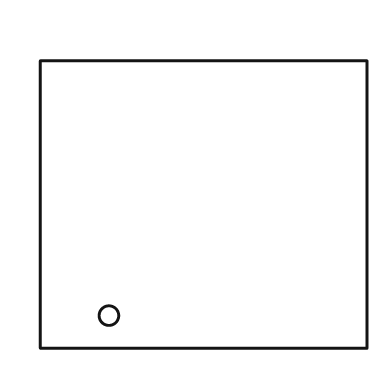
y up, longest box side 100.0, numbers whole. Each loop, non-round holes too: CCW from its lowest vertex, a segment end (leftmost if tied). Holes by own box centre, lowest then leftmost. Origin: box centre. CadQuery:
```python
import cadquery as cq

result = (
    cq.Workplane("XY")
    .moveTo(-50.0, -44.0)
    .lineTo(50.0, -44.0)
    .lineTo(50.0, 44.0)
    .lineTo(-50.0, 44.0)
    .close()
    .moveTo(-29.0, -34.0)
    .circle(3.0)
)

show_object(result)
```